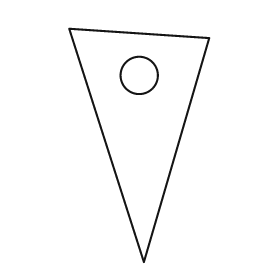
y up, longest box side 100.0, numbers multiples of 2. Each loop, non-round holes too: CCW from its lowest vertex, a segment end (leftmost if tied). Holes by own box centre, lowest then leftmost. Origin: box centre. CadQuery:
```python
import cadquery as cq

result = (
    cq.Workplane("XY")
    .moveTo(2.0, -50.0)
    .lineTo(30.0, 46.0)
    .lineTo(-30.0, 50.0)
    .close()
    .moveTo(0.0, 30.0)
    .circle(8.0)
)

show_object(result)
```